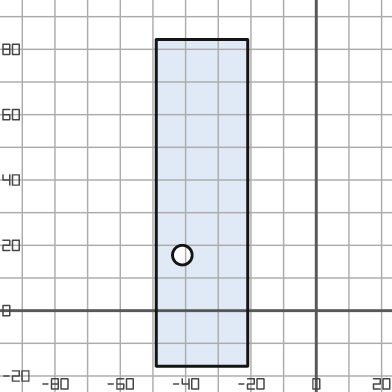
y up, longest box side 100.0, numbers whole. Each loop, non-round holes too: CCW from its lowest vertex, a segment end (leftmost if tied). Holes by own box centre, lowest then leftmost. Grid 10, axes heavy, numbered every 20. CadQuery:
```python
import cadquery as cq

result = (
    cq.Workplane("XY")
    .moveTo(-49.0, -17.0)
    .lineTo(-21.0, -17.0)
    .lineTo(-21.0, 83.0)
    .lineTo(-49.0, 83.0)
    .close()
    .moveTo(-41.0, 17.0)
    .circle(3.0)
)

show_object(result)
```